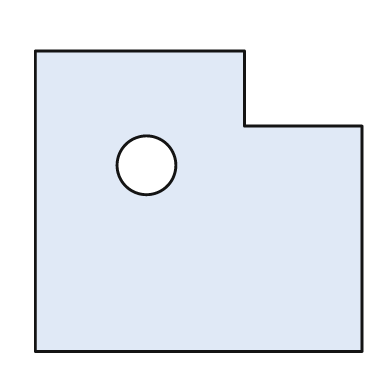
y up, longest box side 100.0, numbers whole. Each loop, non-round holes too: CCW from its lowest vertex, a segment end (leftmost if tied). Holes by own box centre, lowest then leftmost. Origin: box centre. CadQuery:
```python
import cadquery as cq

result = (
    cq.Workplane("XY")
    .moveTo(-50.0, -46.0)
    .lineTo(50.0, -46.0)
    .lineTo(50.0, 23.0)
    .lineTo(14.0, 23.0)
    .lineTo(14.0, 46.0)
    .lineTo(-50.0, 46.0)
    .close()
    .moveTo(-16.0, 11.0)
    .circle(9.0)
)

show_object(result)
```